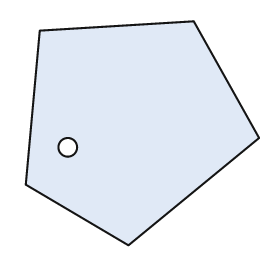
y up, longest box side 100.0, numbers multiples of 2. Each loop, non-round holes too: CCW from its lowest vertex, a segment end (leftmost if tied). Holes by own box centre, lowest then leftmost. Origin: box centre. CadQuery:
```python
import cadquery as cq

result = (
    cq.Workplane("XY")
    .moveTo(-6.0, -48.0)
    .lineTo(50.0, -2.0)
    .lineTo(22.0, 48.0)
    .lineTo(-44.0, 44.0)
    .lineTo(-50.0, -22.0)
    .close()
    .moveTo(-32.0, -6.0)
    .circle(4.0)
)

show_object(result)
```